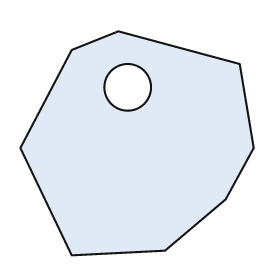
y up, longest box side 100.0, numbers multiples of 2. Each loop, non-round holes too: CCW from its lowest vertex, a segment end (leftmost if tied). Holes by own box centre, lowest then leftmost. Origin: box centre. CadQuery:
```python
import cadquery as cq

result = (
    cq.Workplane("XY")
    .moveTo(-28.0, -48.0)
    .lineTo(12.0, -46.0)
    .lineTo(38.0, -24.0)
    .lineTo(50.0, -2.0)
    .lineTo(44.0, 34.0)
    .lineTo(-8.0, 48.0)
    .lineTo(-28.0, 40.0)
    .lineTo(-50.0, -2.0)
    .close()
    .moveTo(-4.0, 24.0)
    .circle(10.0)
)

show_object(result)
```